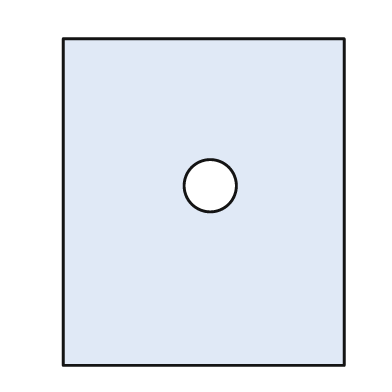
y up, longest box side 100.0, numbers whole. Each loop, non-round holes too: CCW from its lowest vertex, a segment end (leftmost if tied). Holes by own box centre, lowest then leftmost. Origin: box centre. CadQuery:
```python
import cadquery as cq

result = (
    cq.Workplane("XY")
    .moveTo(-43.0, -50.0)
    .lineTo(43.0, -50.0)
    .lineTo(43.0, 50.0)
    .lineTo(-43.0, 50.0)
    .close()
    .moveTo(2.0, 5.0)
    .circle(8.0)
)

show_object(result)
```